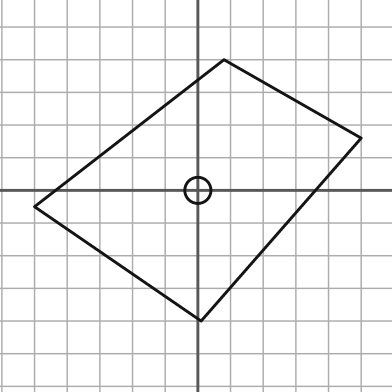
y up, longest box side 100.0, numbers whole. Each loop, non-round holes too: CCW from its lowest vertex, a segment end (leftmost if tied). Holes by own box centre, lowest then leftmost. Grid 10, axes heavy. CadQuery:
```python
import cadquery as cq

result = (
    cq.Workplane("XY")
    .moveTo(1.0, -40.0)
    .lineTo(50.0, 16.0)
    .lineTo(8.0, 40.0)
    .lineTo(-50.0, -5.0)
    .close()
    .moveTo(0.0, 0.0)
    .circle(4.0)
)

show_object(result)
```